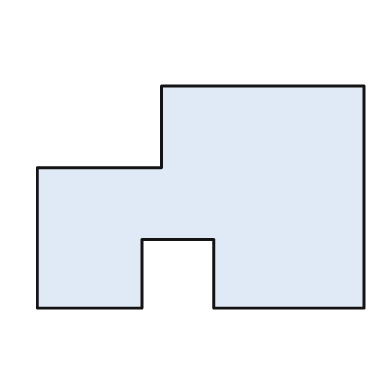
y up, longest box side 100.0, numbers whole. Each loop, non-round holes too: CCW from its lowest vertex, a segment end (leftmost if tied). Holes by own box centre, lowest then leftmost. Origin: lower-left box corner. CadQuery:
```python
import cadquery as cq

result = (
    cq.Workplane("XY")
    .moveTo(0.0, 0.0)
    .lineTo(32.0, 0.0)
    .lineTo(32.0, 21.0)
    .lineTo(54.0, 21.0)
    .lineTo(54.0, 0.0)
    .lineTo(100.0, 0.0)
    .lineTo(100.0, 68.0)
    .lineTo(38.0, 68.0)
    .lineTo(38.0, 43.0)
    .lineTo(0.0, 43.0)
    .close()
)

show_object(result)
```